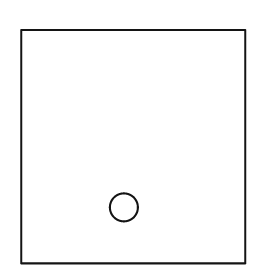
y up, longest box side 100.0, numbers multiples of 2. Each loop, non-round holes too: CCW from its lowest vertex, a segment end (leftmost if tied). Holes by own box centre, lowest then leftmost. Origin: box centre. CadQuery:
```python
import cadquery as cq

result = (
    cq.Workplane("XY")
    .moveTo(-48.0, -50.0)
    .lineTo(48.0, -50.0)
    .lineTo(48.0, 50.0)
    .lineTo(-48.0, 50.0)
    .close()
    .moveTo(-4.0, -26.0)
    .circle(6.0)
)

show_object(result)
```